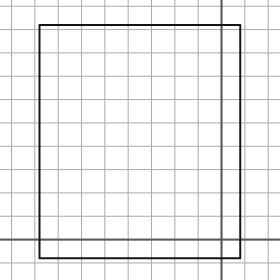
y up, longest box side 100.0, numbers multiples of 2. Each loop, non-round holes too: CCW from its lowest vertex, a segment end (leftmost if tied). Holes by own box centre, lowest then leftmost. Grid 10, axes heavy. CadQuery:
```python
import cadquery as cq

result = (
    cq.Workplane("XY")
    .moveTo(-78.0, -8.0)
    .lineTo(8.0, -8.0)
    .lineTo(8.0, 92.0)
    .lineTo(-78.0, 92.0)
    .close()
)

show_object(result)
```